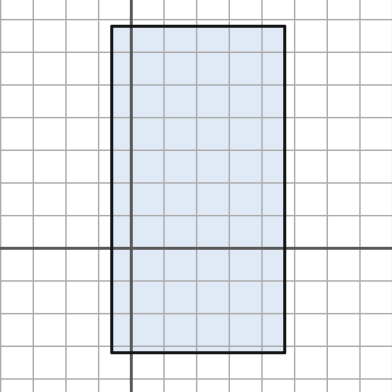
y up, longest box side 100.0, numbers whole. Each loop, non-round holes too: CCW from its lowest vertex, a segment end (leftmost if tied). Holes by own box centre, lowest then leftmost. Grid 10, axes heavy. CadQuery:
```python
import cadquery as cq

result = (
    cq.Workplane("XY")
    .moveTo(-6.0, -32.0)
    .lineTo(47.0, -32.0)
    .lineTo(47.0, 68.0)
    .lineTo(-6.0, 68.0)
    .close()
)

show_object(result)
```